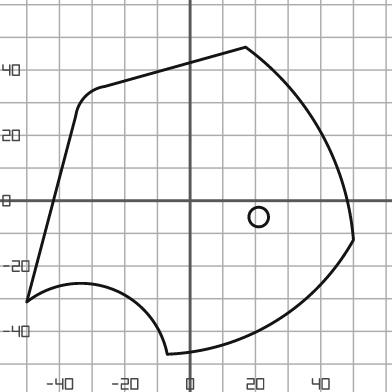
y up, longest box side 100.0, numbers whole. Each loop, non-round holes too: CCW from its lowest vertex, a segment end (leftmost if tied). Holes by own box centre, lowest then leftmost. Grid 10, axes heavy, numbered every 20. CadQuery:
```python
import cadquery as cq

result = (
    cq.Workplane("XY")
    .moveTo(-7.0, -47.0)
    .threePointArc((26.0, -37.0), (50.0, -12.0))
    .threePointArc((40.0, 21.0), (17.0, 47.0))
    .lineTo(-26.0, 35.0)
    .threePointArc((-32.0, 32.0), (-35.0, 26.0))
    .lineTo(-50.0, -31.0)
    .threePointArc((-24.0, -27.0), (-7.0, -47.0))
    .close()
    .moveTo(21.0, -5.0)
    .circle(3.0)
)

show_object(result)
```